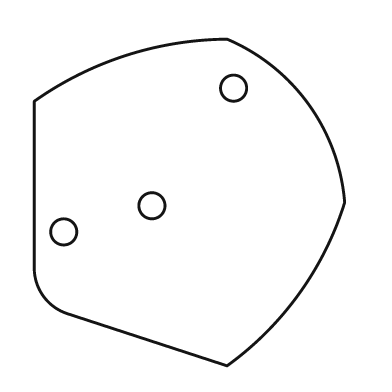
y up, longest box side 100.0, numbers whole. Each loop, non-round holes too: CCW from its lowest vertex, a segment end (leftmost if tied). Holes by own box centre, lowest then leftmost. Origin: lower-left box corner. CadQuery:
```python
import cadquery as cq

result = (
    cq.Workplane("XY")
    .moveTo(59.0, 0.0)
    .threePointArc((81.0, 22.0), (95.0, 50.0))
    .threePointArc((84.0, 80.0), (59.0, 100.0))
    .threePointArc((28.0, 95.0), (0.0, 81.0))
    .lineTo(0.0, 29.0)
    .threePointArc((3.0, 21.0), (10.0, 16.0))
    .close()
    .moveTo(9.0, 41.0)
    .circle(4.0)
    .moveTo(36.0, 49.0)
    .circle(4.0)
    .moveTo(61.0, 85.0)
    .circle(4.0)
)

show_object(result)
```